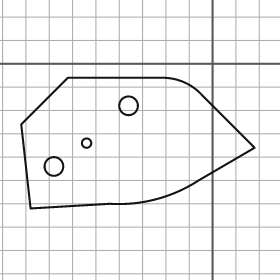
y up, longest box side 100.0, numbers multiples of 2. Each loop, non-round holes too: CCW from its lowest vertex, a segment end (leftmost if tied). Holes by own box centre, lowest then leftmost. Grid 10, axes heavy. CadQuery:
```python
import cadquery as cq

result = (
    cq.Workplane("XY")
    .moveTo(-78.0, -62.0)
    .lineTo(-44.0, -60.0)
    .threePointArc((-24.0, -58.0), (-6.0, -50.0))
    .lineTo(18.0, -36.0)
    .lineTo(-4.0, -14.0)
    .threePointArc((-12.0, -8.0), (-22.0, -6.0))
    .lineTo(-62.0, -6.0)
    .lineTo(-82.0, -26.0)
    .close()
    .moveTo(-68.0, -44.0)
    .circle(4.0)
    .moveTo(-54.0, -34.0)
    .circle(2.0)
    .moveTo(-36.0, -18.0)
    .circle(4.0)
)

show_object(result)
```